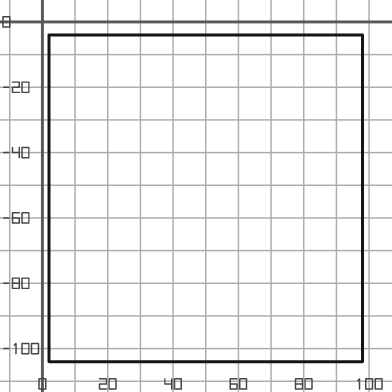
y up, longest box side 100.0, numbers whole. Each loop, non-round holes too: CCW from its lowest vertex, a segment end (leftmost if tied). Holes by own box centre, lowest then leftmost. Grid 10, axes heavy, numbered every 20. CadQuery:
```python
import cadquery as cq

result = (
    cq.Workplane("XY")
    .moveTo(2.0, -104.0)
    .lineTo(98.0, -104.0)
    .lineTo(98.0, -4.0)
    .lineTo(2.0, -4.0)
    .close()
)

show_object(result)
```